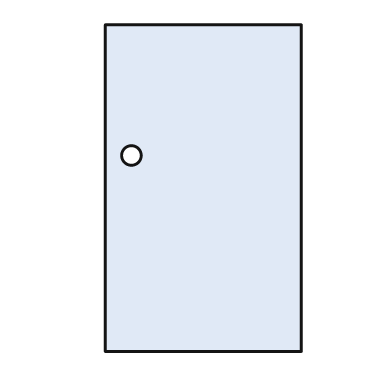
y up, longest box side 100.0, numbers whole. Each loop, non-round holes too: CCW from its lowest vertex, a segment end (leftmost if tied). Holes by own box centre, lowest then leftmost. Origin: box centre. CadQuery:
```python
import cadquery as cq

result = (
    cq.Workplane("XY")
    .moveTo(-30.0, -50.0)
    .lineTo(30.0, -50.0)
    .lineTo(30.0, 50.0)
    .lineTo(-30.0, 50.0)
    .close()
    .moveTo(-22.0, 10.0)
    .circle(3.0)
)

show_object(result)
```